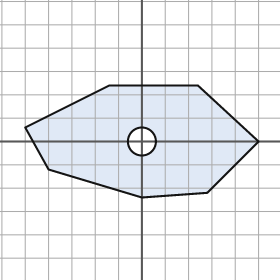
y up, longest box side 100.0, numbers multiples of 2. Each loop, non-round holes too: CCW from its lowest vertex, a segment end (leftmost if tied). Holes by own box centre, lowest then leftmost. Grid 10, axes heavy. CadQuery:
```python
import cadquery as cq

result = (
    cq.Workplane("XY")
    .moveTo(0.0, -24.0)
    .lineTo(28.0, -22.0)
    .lineTo(50.0, 0.0)
    .lineTo(24.0, 24.0)
    .lineTo(-14.0, 24.0)
    .lineTo(-50.0, 6.0)
    .lineTo(-40.0, -12.0)
    .close()
    .moveTo(0.0, 0.0)
    .circle(6.0)
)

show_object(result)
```